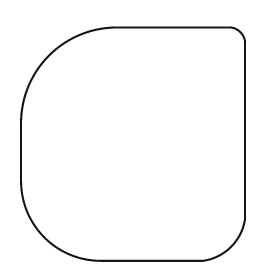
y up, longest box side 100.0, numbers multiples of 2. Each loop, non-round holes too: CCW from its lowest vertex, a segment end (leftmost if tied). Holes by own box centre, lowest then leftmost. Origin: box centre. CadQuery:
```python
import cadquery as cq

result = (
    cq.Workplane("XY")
    .moveTo(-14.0, -50.0)
    .lineTo(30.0, -50.0)
    .threePointArc((42.0, -44.0), (48.0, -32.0))
    .lineTo(48.0, 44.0)
    .threePointArc((46.0, 48.0), (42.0, 50.0))
    .lineTo(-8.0, 50.0)
    .threePointArc((-36.0, 38.0), (-48.0, 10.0))
    .lineTo(-48.0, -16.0)
    .threePointArc((-38.0, -40.0), (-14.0, -50.0))
    .close()
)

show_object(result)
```